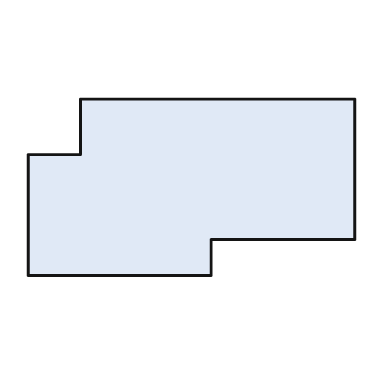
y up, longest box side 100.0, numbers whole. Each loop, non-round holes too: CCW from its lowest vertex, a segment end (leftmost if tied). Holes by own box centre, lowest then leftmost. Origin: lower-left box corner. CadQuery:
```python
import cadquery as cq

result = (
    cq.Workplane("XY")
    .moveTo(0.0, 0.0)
    .lineTo(56.0, 0.0)
    .lineTo(56.0, 11.0)
    .lineTo(100.0, 11.0)
    .lineTo(100.0, 54.0)
    .lineTo(16.0, 54.0)
    .lineTo(16.0, 37.0)
    .lineTo(0.0, 37.0)
    .close()
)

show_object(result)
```